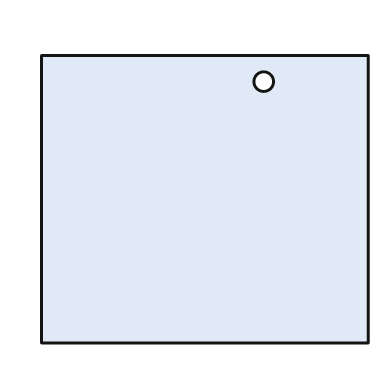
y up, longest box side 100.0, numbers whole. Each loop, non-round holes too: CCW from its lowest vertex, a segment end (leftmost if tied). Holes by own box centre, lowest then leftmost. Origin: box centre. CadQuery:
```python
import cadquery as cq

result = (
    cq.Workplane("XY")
    .moveTo(-50.0, -44.0)
    .lineTo(50.0, -44.0)
    .lineTo(50.0, 44.0)
    .lineTo(-50.0, 44.0)
    .close()
    .moveTo(18.0, 36.0)
    .circle(3.0)
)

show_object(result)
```